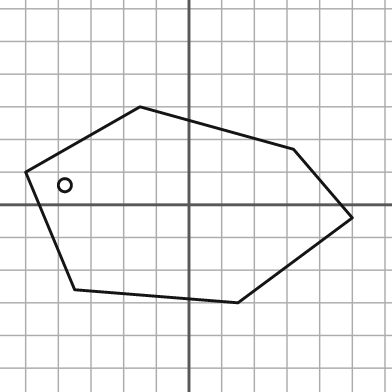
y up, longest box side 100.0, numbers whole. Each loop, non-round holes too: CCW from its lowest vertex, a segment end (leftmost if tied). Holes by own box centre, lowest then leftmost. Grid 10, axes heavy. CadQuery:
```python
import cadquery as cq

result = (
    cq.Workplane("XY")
    .moveTo(15.0, -30.0)
    .lineTo(50.0, -4.0)
    .lineTo(32.0, 17.0)
    .lineTo(-15.0, 30.0)
    .lineTo(-50.0, 10.0)
    .lineTo(-35.0, -26.0)
    .close()
    .moveTo(-38.0, 6.0)
    .circle(2.0)
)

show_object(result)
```